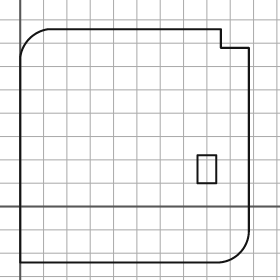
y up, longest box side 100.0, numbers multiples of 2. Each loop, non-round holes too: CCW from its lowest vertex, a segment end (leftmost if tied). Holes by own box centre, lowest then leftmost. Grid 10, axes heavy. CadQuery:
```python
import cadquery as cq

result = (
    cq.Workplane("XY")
    .moveTo(0.0, -24.0)
    .lineTo(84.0, -24.0)
    .threePointArc((94.0, -20.0), (98.0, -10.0))
    .lineTo(98.0, 68.0)
    .lineTo(86.0, 68.0)
    .lineTo(86.0, 76.0)
    .lineTo(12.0, 76.0)
    .threePointArc((4.0, 72.0), (0.0, 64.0))
    .close()
    .moveTo(76.0, 10.0)
    .lineTo(84.0, 10.0)
    .lineTo(84.0, 22.0)
    .lineTo(76.0, 22.0)
    .close()
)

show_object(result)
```